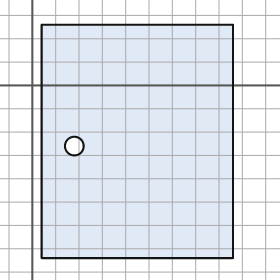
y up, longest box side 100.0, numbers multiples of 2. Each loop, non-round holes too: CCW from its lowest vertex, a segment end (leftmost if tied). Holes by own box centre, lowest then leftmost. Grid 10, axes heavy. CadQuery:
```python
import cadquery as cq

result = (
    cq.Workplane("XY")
    .moveTo(4.0, -74.0)
    .lineTo(86.0, -74.0)
    .lineTo(86.0, 26.0)
    .lineTo(4.0, 26.0)
    .close()
    .moveTo(18.0, -26.0)
    .circle(4.0)
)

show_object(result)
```